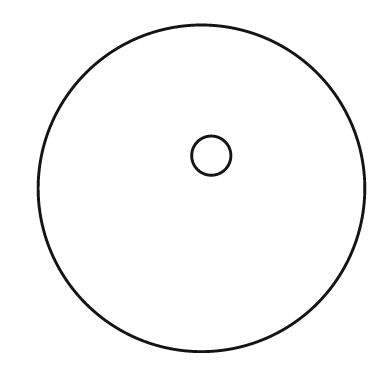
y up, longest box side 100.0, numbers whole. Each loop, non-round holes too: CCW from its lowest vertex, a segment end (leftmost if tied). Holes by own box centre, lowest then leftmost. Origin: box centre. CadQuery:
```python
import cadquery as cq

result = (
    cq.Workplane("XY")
    .moveTo(0.0, 0.0)
    .circle(50.0)
    .moveTo(3.0, 10.0)
    .circle(6.0)
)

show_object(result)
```